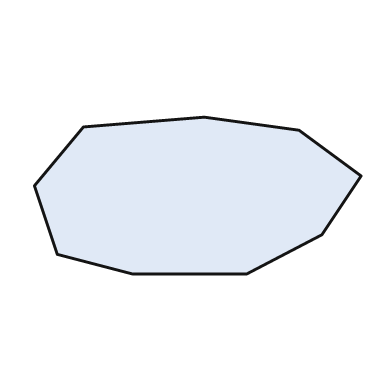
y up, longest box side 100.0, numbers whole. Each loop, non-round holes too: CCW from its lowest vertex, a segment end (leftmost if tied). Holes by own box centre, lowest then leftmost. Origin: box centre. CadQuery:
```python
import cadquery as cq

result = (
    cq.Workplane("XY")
    .moveTo(-20.0, -24.0)
    .lineTo(15.0, -24.0)
    .lineTo(38.0, -12.0)
    .lineTo(50.0, 6.0)
    .lineTo(31.0, 20.0)
    .lineTo(2.0, 24.0)
    .lineTo(-35.0, 21.0)
    .lineTo(-50.0, 3.0)
    .lineTo(-43.0, -18.0)
    .close()
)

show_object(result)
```